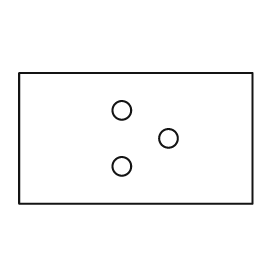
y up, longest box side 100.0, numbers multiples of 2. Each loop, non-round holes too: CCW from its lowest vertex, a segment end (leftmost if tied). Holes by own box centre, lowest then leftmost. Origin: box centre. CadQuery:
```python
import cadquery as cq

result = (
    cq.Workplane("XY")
    .moveTo(-50.0, -28.0)
    .lineTo(50.0, -28.0)
    .lineTo(50.0, 28.0)
    .lineTo(-50.0, 28.0)
    .close()
    .moveTo(-6.0, -12.0)
    .circle(4.0)
    .moveTo(14.0, 0.0)
    .circle(4.0)
    .moveTo(-6.0, 12.0)
    .circle(4.0)
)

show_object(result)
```